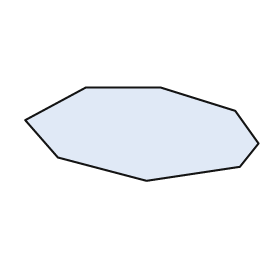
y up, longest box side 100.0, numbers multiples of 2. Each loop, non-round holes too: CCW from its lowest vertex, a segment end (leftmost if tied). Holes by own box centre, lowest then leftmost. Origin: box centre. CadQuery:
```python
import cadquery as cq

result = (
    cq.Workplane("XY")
    .moveTo(2.0, -20.0)
    .lineTo(42.0, -14.0)
    .lineTo(50.0, -4.0)
    .lineTo(40.0, 10.0)
    .lineTo(8.0, 20.0)
    .lineTo(-24.0, 20.0)
    .lineTo(-50.0, 6.0)
    .lineTo(-36.0, -10.0)
    .close()
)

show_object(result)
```